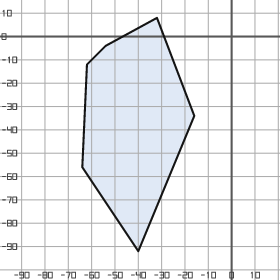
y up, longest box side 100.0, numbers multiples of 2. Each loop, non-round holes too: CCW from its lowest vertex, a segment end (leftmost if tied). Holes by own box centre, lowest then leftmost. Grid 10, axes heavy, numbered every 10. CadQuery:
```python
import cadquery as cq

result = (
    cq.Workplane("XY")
    .moveTo(-40.0, -92.0)
    .lineTo(-16.0, -34.0)
    .lineTo(-32.0, 8.0)
    .lineTo(-54.0, -4.0)
    .lineTo(-62.0, -12.0)
    .lineTo(-64.0, -56.0)
    .close()
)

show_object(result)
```